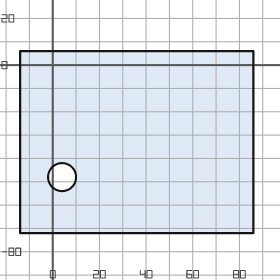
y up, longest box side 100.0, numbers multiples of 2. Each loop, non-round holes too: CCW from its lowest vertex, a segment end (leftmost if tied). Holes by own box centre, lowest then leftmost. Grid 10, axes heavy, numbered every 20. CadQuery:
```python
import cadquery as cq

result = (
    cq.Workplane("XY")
    .moveTo(-14.0, -72.0)
    .lineTo(86.0, -72.0)
    .lineTo(86.0, 6.0)
    .lineTo(-14.0, 6.0)
    .close()
    .moveTo(4.0, -48.0)
    .circle(6.0)
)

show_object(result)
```